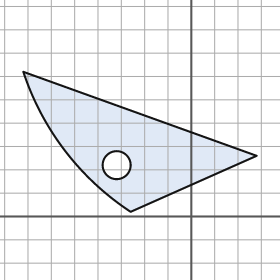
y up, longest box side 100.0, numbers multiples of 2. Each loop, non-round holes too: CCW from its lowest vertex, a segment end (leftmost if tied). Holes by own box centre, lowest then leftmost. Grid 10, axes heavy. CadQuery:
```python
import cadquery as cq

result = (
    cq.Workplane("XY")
    .moveTo(-26.0, 2.0)
    .lineTo(28.0, 26.0)
    .lineTo(-72.0, 62.0)
    .threePointArc((-54.0, 28.0), (-26.0, 2.0))
    .close()
    .moveTo(-32.0, 22.0)
    .circle(6.0)
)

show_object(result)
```